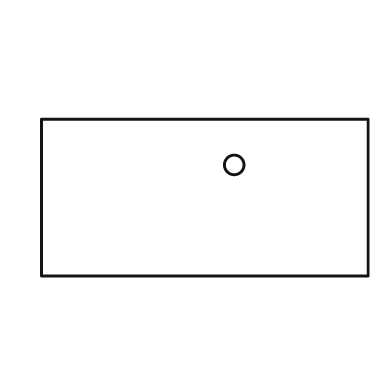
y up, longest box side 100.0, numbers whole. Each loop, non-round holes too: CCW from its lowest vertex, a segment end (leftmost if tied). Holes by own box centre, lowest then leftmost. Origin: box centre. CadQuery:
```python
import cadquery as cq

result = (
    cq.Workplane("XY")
    .moveTo(-50.0, -24.0)
    .lineTo(50.0, -24.0)
    .lineTo(50.0, 24.0)
    .lineTo(-50.0, 24.0)
    .close()
    .moveTo(9.0, 10.0)
    .circle(3.0)
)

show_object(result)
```